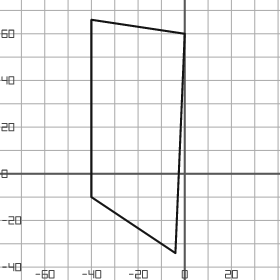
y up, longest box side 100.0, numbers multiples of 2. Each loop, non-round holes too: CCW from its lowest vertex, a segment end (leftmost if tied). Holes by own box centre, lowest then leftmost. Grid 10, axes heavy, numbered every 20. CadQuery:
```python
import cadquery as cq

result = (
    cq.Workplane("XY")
    .moveTo(-4.0, -34.0)
    .lineTo(0.0, 60.0)
    .lineTo(-40.0, 66.0)
    .lineTo(-40.0, -10.0)
    .close()
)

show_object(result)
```